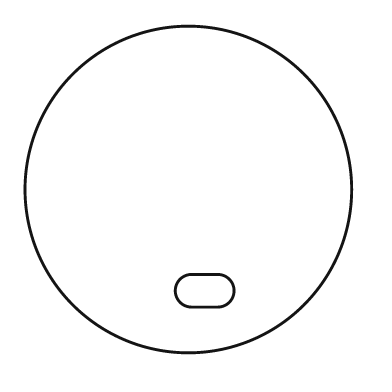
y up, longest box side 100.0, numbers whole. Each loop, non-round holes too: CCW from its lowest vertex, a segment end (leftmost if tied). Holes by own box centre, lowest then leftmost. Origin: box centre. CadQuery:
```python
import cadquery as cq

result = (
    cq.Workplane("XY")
    .moveTo(0.0, 0.0)
    .circle(50.0)
    .moveTo(1.0, -36.0)
    .lineTo(9.0, -36.0)
    .threePointArc((14.0, -31.0), (9.0, -26.0))
    .lineTo(1.0, -26.0)
    .threePointArc((-4.0, -31.0), (1.0, -36.0))
    .close()
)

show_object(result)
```